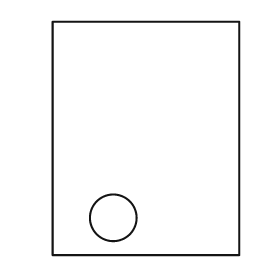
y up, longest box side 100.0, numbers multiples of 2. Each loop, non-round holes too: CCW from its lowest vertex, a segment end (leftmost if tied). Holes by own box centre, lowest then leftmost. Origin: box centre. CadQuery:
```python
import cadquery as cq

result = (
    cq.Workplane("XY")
    .moveTo(-40.0, -50.0)
    .lineTo(40.0, -50.0)
    .lineTo(40.0, 50.0)
    .lineTo(-40.0, 50.0)
    .close()
    .moveTo(-14.0, -34.0)
    .circle(10.0)
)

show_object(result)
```